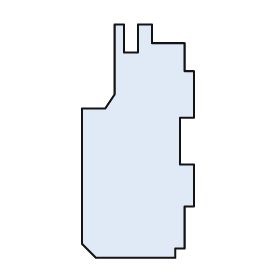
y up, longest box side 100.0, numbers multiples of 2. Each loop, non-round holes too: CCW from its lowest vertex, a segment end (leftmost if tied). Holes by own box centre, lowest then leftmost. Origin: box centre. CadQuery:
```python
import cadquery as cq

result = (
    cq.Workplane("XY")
    .moveTo(-18.0, -50.0)
    .lineTo(16.0, -50.0)
    .lineTo(16.0, -46.0)
    .lineTo(20.0, -46.0)
    .lineTo(20.0, -28.0)
    .lineTo(24.0, -28.0)
    .lineTo(24.0, -10.0)
    .lineTo(18.0, -10.0)
    .lineTo(18.0, 10.0)
    .lineTo(24.0, 10.0)
    .lineTo(24.0, 30.0)
    .lineTo(20.0, 30.0)
    .lineTo(20.0, 42.0)
    .lineTo(6.0, 42.0)
    .lineTo(6.0, 50.0)
    .lineTo(0.0, 50.0)
    .lineTo(0.0, 38.0)
    .lineTo(-6.0, 38.0)
    .lineTo(-6.0, 50.0)
    .lineTo(-10.0, 50.0)
    .lineTo(-10.0, 20.0)
    .lineTo(-14.0, 14.0)
    .lineTo(-24.0, 14.0)
    .lineTo(-24.0, -44.0)
    .close()
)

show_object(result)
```